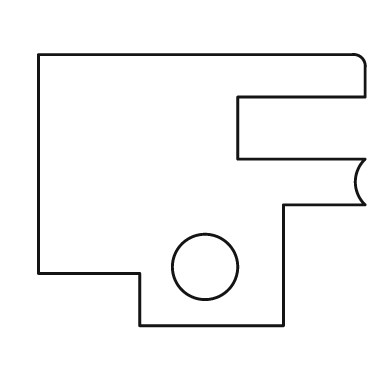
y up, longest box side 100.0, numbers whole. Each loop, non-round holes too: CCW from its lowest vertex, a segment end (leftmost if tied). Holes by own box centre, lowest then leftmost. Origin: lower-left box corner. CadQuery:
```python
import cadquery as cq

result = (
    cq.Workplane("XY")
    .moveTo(31.0, 0.0)
    .lineTo(75.0, 0.0)
    .lineTo(75.0, 37.0)
    .lineTo(100.0, 37.0)
    .threePointArc((97.0, 44.0), (100.0, 51.0))
    .lineTo(61.0, 51.0)
    .lineTo(61.0, 70.0)
    .lineTo(100.0, 70.0)
    .lineTo(100.0, 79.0)
    .threePointArc((99.0, 82.0), (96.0, 83.0))
    .lineTo(0.0, 83.0)
    .lineTo(0.0, 16.0)
    .lineTo(31.0, 16.0)
    .close()
    .moveTo(51.0, 18.0)
    .circle(10.0)
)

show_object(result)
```